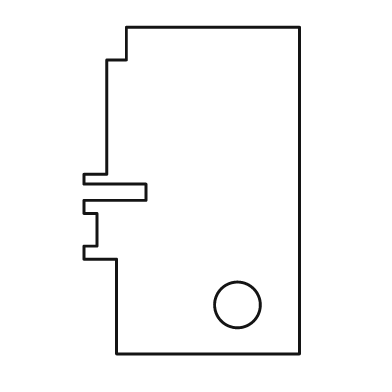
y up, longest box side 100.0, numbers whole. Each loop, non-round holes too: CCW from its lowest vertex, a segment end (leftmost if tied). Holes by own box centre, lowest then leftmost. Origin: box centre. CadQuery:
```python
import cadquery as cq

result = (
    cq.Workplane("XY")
    .moveTo(-23.0, -50.0)
    .lineTo(33.0, -50.0)
    .lineTo(33.0, 50.0)
    .lineTo(-20.0, 50.0)
    .lineTo(-20.0, 40.0)
    .lineTo(-26.0, 40.0)
    .lineTo(-26.0, 5.0)
    .lineTo(-33.0, 5.0)
    .lineTo(-33.0, 2.0)
    .lineTo(-14.0, 2.0)
    .lineTo(-14.0, -3.0)
    .lineTo(-33.0, -3.0)
    .lineTo(-33.0, -7.0)
    .lineTo(-29.0, -7.0)
    .lineTo(-29.0, -17.0)
    .lineTo(-33.0, -17.0)
    .lineTo(-33.0, -21.0)
    .lineTo(-23.0, -21.0)
    .close()
    .moveTo(14.0, -35.0)
    .circle(7.0)
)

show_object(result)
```